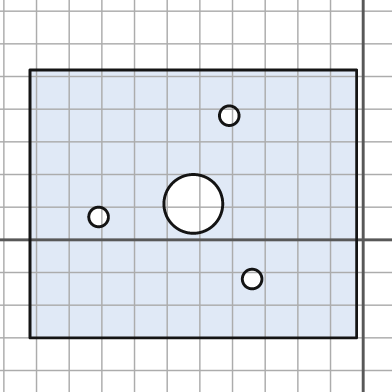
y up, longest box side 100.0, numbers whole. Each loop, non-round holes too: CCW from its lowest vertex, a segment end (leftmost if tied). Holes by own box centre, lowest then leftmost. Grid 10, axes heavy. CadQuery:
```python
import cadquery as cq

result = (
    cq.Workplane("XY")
    .moveTo(-102.0, -30.0)
    .lineTo(-2.0, -30.0)
    .lineTo(-2.0, 52.0)
    .lineTo(-102.0, 52.0)
    .close()
    .moveTo(-34.0, -12.0)
    .circle(3.0)
    .moveTo(-81.0, 7.0)
    .circle(3.0)
    .moveTo(-52.0, 11.0)
    .circle(9.0)
    .moveTo(-41.0, 38.0)
    .circle(3.0)
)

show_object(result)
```